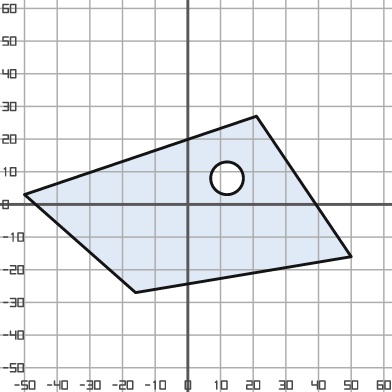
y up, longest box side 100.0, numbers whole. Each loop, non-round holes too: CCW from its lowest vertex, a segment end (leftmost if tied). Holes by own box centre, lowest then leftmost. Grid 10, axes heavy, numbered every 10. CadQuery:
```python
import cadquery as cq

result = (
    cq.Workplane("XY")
    .moveTo(-16.0, -27.0)
    .lineTo(50.0, -16.0)
    .lineTo(21.0, 27.0)
    .lineTo(-50.0, 3.0)
    .close()
    .moveTo(12.0, 8.0)
    .circle(5.0)
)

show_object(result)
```